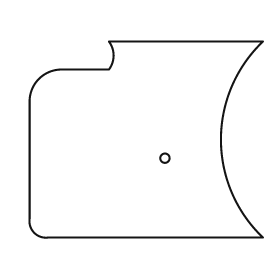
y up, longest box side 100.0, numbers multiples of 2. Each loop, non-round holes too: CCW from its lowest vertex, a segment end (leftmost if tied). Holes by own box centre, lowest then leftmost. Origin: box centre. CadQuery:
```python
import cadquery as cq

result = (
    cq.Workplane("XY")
    .moveTo(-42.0, -42.0)
    .lineTo(50.0, -42.0)
    .threePointArc((32.0, 0.0), (50.0, 42.0))
    .lineTo(-16.0, 42.0)
    .threePointArc((-14.0, 36.0), (-16.0, 30.0))
    .lineTo(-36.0, 30.0)
    .threePointArc((-46.0, 26.0), (-50.0, 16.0))
    .lineTo(-50.0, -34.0)
    .threePointArc((-48.0, -40.0), (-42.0, -42.0))
    .close()
    .moveTo(8.0, -8.0)
    .circle(2.0)
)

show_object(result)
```